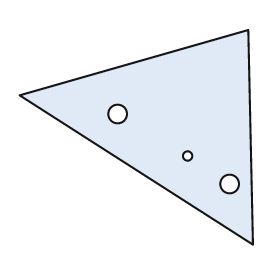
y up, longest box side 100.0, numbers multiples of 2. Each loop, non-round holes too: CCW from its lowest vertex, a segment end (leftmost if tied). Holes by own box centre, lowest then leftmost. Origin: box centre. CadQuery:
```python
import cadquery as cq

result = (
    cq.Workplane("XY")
    .moveTo(50.0, -46.0)
    .lineTo(48.0, 46.0)
    .lineTo(-50.0, 18.0)
    .close()
    .moveTo(40.0, -20.0)
    .circle(4.0)
    .moveTo(22.0, -8.0)
    .circle(2.0)
    .moveTo(-8.0, 10.0)
    .circle(4.0)
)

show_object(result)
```